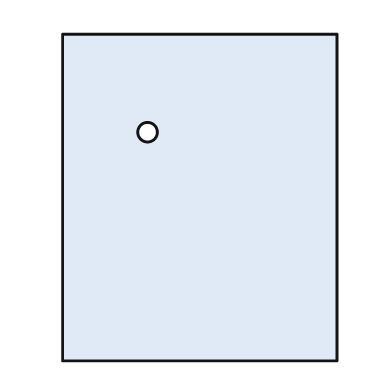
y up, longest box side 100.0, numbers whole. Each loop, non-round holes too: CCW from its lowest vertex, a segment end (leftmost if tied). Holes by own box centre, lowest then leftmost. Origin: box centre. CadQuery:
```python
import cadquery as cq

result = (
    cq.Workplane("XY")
    .moveTo(-42.0, -50.0)
    .lineTo(42.0, -50.0)
    .lineTo(42.0, 50.0)
    .lineTo(-42.0, 50.0)
    .close()
    .moveTo(-16.0, 20.0)
    .circle(3.0)
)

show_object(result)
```